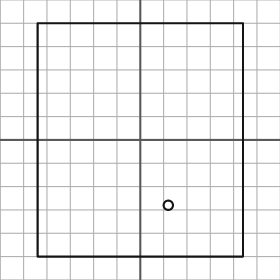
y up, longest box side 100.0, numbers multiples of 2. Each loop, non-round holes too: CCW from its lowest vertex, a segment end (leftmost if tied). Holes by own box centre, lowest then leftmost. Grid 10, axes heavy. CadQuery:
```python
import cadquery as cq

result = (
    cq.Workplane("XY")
    .moveTo(-44.0, -50.0)
    .lineTo(44.0, -50.0)
    .lineTo(44.0, 50.0)
    .lineTo(-44.0, 50.0)
    .close()
    .moveTo(12.0, -28.0)
    .circle(2.0)
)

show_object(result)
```